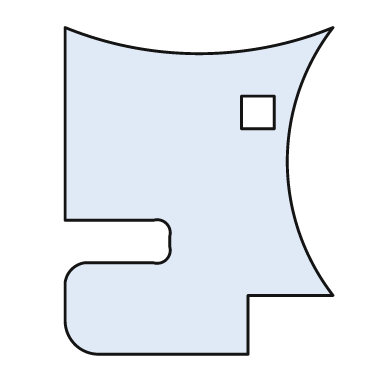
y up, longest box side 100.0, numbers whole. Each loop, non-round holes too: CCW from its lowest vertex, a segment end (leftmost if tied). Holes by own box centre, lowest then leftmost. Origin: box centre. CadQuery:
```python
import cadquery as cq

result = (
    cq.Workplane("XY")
    .moveTo(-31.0, -50.0)
    .lineTo(15.0, -50.0)
    .lineTo(15.0, -32.0)
    .lineTo(41.0, -32.0)
    .threePointArc((27.0, 9.0), (41.0, 50.0))
    .threePointArc((0.0, 42.0), (-41.0, 50.0))
    .lineTo(-41.0, -9.0)
    .lineTo(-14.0, -9.0)
    .threePointArc((-10.0, -10.0), (-9.0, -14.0))
    .lineTo(-9.0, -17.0)
    .threePointArc((-10.0, -21.0), (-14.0, -22.0))
    .lineTo(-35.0, -22.0)
    .threePointArc((-39.0, -24.0), (-41.0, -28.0))
    .lineTo(-41.0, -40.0)
    .threePointArc((-38.0, -47.0), (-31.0, -50.0))
    .close()
    .moveTo(13.0, 19.0)
    .lineTo(23.0, 19.0)
    .lineTo(23.0, 29.0)
    .lineTo(13.0, 29.0)
    .close()
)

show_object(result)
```